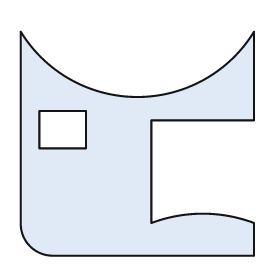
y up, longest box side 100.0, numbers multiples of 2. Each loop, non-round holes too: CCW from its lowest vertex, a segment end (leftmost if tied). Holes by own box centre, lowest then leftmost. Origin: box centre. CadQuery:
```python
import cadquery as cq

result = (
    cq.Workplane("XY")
    .moveTo(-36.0, -48.0)
    .lineTo(50.0, -48.0)
    .lineTo(50.0, -34.0)
    .threePointArc((28.0, -30.0), (6.0, -34.0))
    .lineTo(6.0, 10.0)
    .lineTo(50.0, 10.0)
    .lineTo(50.0, 48.0)
    .threePointArc((0.0, 20.0), (-50.0, 48.0))
    .lineTo(-50.0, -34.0)
    .threePointArc((-46.0, -44.0), (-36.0, -48.0))
    .close()
    .moveTo(-42.0, -2.0)
    .lineTo(-22.0, -2.0)
    .lineTo(-22.0, 14.0)
    .lineTo(-42.0, 14.0)
    .close()
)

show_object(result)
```